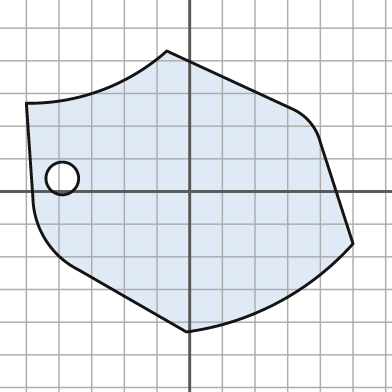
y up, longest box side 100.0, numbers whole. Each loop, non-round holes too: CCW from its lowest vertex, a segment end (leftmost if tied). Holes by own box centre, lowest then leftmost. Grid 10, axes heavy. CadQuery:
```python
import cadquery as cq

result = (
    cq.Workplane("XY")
    .moveTo(-1.0, -43.0)
    .threePointArc((27.0, -34.0), (50.0, -16.0))
    .lineTo(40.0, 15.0)
    .threePointArc((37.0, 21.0), (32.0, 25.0))
    .lineTo(-7.0, 43.0)
    .threePointArc((-27.0, 31.0), (-50.0, 27.0))
    .lineTo(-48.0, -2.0)
    .threePointArc((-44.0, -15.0), (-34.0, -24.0))
    .close()
    .moveTo(-39.0, 4.0)
    .circle(5.0)
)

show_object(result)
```